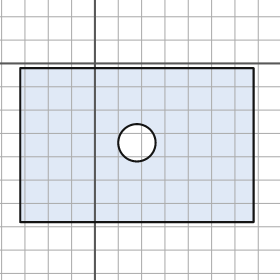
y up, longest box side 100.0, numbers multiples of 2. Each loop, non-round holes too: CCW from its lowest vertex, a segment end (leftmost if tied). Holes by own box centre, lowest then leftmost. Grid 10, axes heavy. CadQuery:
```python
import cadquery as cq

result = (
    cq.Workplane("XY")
    .moveTo(-32.0, -68.0)
    .lineTo(68.0, -68.0)
    .lineTo(68.0, -2.0)
    .lineTo(-32.0, -2.0)
    .close()
    .moveTo(18.0, -34.0)
    .circle(8.0)
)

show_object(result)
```